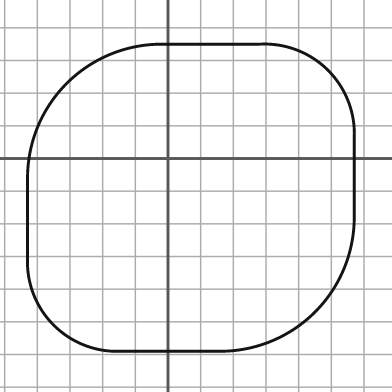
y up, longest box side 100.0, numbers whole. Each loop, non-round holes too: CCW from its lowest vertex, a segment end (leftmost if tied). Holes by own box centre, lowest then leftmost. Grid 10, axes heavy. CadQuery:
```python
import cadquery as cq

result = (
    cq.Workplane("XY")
    .moveTo(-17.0, -59.0)
    .lineTo(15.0, -59.0)
    .threePointArc((45.0, -47.0), (57.0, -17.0))
    .lineTo(57.0, 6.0)
    .threePointArc((49.0, 27.0), (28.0, 35.0))
    .lineTo(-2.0, 35.0)
    .threePointArc((-31.0, 23.0), (-43.0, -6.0))
    .lineTo(-43.0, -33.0)
    .threePointArc((-35.0, -51.0), (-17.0, -59.0))
    .close()
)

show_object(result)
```